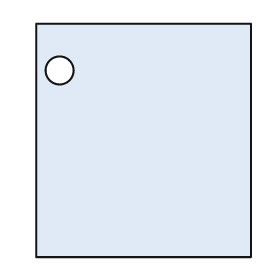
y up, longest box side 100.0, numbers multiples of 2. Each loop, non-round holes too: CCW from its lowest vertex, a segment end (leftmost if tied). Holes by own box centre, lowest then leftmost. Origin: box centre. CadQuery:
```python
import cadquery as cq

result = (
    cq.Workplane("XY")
    .moveTo(-46.0, -50.0)
    .lineTo(46.0, -50.0)
    .lineTo(46.0, 50.0)
    .lineTo(-46.0, 50.0)
    .close()
    .moveTo(-36.0, 30.0)
    .circle(6.0)
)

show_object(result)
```